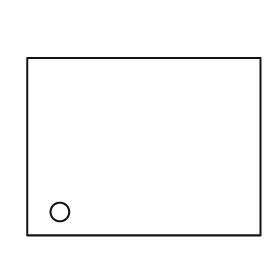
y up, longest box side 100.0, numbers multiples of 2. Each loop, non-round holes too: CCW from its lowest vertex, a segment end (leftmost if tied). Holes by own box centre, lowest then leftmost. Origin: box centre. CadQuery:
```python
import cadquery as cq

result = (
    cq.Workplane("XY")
    .moveTo(-50.0, -38.0)
    .lineTo(50.0, -38.0)
    .lineTo(50.0, 38.0)
    .lineTo(-50.0, 38.0)
    .close()
    .moveTo(-36.0, -28.0)
    .circle(4.0)
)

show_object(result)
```